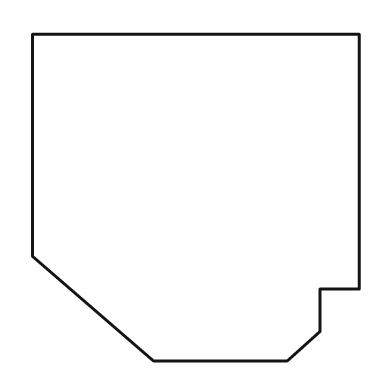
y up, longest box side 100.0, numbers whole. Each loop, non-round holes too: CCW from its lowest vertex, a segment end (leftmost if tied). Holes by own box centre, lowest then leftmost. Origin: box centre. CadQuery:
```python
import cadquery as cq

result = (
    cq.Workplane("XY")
    .moveTo(-13.0, -50.0)
    .lineTo(28.0, -50.0)
    .lineTo(38.0, -41.0)
    .lineTo(38.0, -28.0)
    .lineTo(50.0, -28.0)
    .lineTo(50.0, 50.0)
    .lineTo(-50.0, 50.0)
    .lineTo(-50.0, -18.0)
    .close()
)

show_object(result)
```